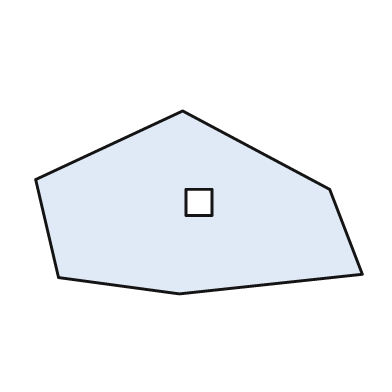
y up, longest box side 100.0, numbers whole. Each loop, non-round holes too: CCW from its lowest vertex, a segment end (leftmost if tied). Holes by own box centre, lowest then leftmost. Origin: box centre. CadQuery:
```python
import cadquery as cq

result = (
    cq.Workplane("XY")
    .moveTo(-6.0, -28.0)
    .lineTo(50.0, -22.0)
    .lineTo(40.0, 4.0)
    .lineTo(-5.0, 28.0)
    .lineTo(-50.0, 7.0)
    .lineTo(-43.0, -23.0)
    .close()
    .moveTo(-4.0, -4.0)
    .lineTo(4.0, -4.0)
    .lineTo(4.0, 4.0)
    .lineTo(-4.0, 4.0)
    .close()
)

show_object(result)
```